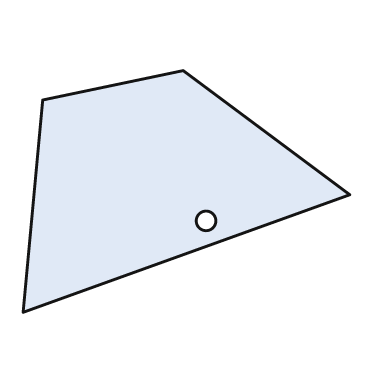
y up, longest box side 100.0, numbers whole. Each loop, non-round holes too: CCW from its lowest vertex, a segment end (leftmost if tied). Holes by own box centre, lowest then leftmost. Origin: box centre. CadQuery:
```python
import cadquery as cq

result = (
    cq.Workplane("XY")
    .moveTo(-50.0, -37.0)
    .lineTo(50.0, -1.0)
    .lineTo(-1.0, 37.0)
    .lineTo(-44.0, 28.0)
    .close()
    .moveTo(6.0, -9.0)
    .circle(3.0)
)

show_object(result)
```